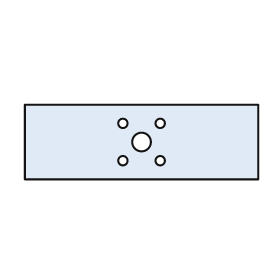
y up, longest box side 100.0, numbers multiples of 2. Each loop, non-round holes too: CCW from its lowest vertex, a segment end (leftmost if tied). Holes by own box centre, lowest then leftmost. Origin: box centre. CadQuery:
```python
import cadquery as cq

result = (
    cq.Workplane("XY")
    .moveTo(-50.0, -16.0)
    .lineTo(50.0, -16.0)
    .lineTo(50.0, 16.0)
    .lineTo(-50.0, 16.0)
    .close()
    .moveTo(-8.0, -8.0)
    .circle(2.0)
    .moveTo(8.0, -8.0)
    .circle(2.0)
    .moveTo(0.0, 0.0)
    .circle(4.0)
    .moveTo(-8.0, 8.0)
    .circle(2.0)
    .moveTo(8.0, 8.0)
    .circle(2.0)
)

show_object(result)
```